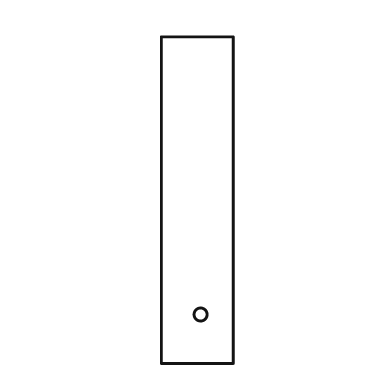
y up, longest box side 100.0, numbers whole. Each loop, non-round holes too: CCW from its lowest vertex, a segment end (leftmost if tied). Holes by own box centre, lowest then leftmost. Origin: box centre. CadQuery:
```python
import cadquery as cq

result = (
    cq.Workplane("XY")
    .moveTo(-11.0, -50.0)
    .lineTo(11.0, -50.0)
    .lineTo(11.0, 50.0)
    .lineTo(-11.0, 50.0)
    .close()
    .moveTo(1.0, -35.0)
    .circle(2.0)
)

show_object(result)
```